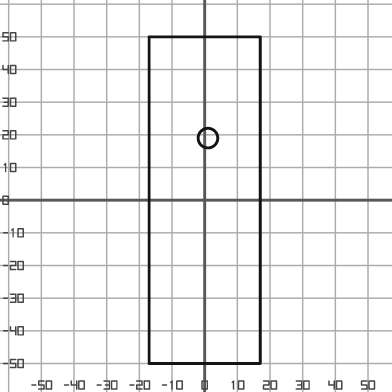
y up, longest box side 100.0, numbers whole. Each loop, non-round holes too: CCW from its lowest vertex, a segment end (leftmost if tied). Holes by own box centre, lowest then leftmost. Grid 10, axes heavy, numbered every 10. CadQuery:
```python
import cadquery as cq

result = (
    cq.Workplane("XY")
    .moveTo(-17.0, -50.0)
    .lineTo(17.0, -50.0)
    .lineTo(17.0, 50.0)
    .lineTo(-17.0, 50.0)
    .close()
    .moveTo(1.0, 19.0)
    .circle(3.0)
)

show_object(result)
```